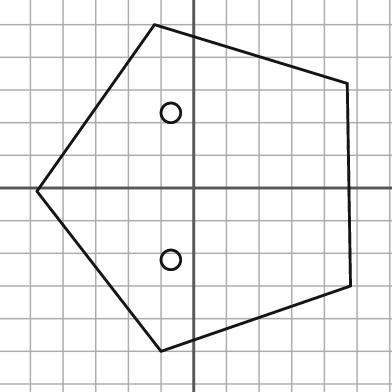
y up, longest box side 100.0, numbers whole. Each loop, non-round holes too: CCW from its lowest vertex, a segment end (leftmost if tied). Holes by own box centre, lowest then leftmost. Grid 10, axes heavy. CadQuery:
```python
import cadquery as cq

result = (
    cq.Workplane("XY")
    .moveTo(-10.0, -50.0)
    .lineTo(48.0, -30.0)
    .lineTo(47.0, 32.0)
    .lineTo(-12.0, 50.0)
    .lineTo(-48.0, -1.0)
    .close()
    .moveTo(-7.0, -22.0)
    .circle(3.0)
    .moveTo(-7.0, 23.0)
    .circle(3.0)
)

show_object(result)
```